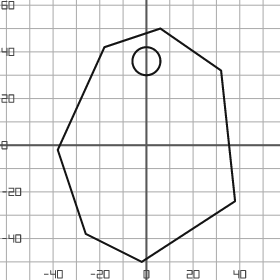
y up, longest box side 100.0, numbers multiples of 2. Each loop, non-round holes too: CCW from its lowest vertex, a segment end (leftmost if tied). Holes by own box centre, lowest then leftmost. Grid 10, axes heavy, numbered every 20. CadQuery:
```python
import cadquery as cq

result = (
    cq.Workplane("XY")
    .moveTo(-2.0, -50.0)
    .lineTo(38.0, -24.0)
    .lineTo(32.0, 32.0)
    .lineTo(6.0, 50.0)
    .lineTo(-18.0, 42.0)
    .lineTo(-38.0, -2.0)
    .lineTo(-26.0, -38.0)
    .close()
    .moveTo(0.0, 36.0)
    .circle(6.0)
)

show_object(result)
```